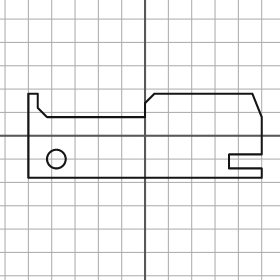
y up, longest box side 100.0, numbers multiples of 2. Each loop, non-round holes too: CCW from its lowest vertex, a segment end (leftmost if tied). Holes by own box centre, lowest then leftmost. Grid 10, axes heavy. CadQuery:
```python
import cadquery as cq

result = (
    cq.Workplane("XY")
    .moveTo(-50.0, -18.0)
    .lineTo(50.0, -18.0)
    .lineTo(50.0, -14.0)
    .lineTo(36.0, -14.0)
    .lineTo(36.0, -8.0)
    .lineTo(50.0, -8.0)
    .lineTo(50.0, 8.0)
    .lineTo(46.0, 18.0)
    .lineTo(4.0, 18.0)
    .lineTo(0.0, 14.0)
    .lineTo(0.0, 8.0)
    .lineTo(-42.0, 8.0)
    .lineTo(-46.0, 12.0)
    .lineTo(-46.0, 18.0)
    .lineTo(-50.0, 18.0)
    .close()
    .moveTo(-38.0, -10.0)
    .circle(4.0)
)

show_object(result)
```